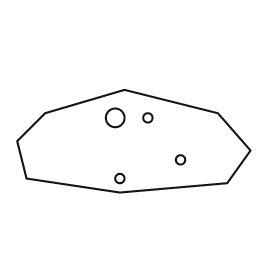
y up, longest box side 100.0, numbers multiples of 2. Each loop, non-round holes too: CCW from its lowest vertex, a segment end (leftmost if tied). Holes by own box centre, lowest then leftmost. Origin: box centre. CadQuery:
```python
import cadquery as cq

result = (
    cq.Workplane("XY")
    .moveTo(-6.0, -22.0)
    .lineTo(40.0, -18.0)
    .lineTo(50.0, -4.0)
    .lineTo(36.0, 12.0)
    .lineTo(-4.0, 22.0)
    .lineTo(-38.0, 12.0)
    .lineTo(-50.0, 0.0)
    .lineTo(-46.0, -16.0)
    .close()
    .moveTo(-6.0, -16.0)
    .circle(2.0)
    .moveTo(20.0, -8.0)
    .circle(2.0)
    .moveTo(-8.0, 10.0)
    .circle(4.0)
    .moveTo(6.0, 10.0)
    .circle(2.0)
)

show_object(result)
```